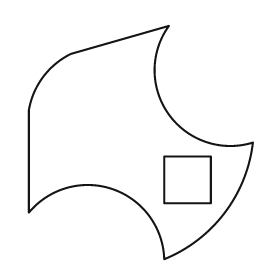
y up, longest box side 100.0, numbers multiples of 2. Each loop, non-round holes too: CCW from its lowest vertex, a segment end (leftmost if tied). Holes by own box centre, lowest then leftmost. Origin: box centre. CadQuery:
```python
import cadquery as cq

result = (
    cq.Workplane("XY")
    .moveTo(10.0, -50.0)
    .threePointArc((36.0, -30.0), (48.0, 0.0))
    .threePointArc((12.0, 12.0), (12.0, 50.0))
    .lineTo(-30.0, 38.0)
    .threePointArc((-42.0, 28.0), (-48.0, 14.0))
    .lineTo(-48.0, -30.0)
    .threePointArc((-12.0, -20.0), (10.0, -50.0))
    .close()
    .moveTo(10.0, -26.0)
    .lineTo(30.0, -26.0)
    .lineTo(30.0, -6.0)
    .lineTo(10.0, -6.0)
    .close()
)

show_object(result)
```